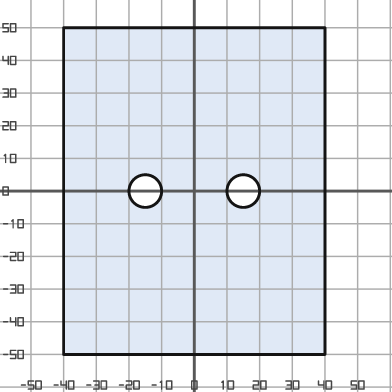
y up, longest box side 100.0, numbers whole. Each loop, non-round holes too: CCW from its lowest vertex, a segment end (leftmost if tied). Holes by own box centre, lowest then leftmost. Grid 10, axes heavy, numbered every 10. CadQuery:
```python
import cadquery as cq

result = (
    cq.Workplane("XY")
    .moveTo(-40.0, -50.0)
    .lineTo(40.0, -50.0)
    .lineTo(40.0, 50.0)
    .lineTo(-40.0, 50.0)
    .close()
    .moveTo(-15.0, 0.0)
    .circle(5.0)
    .moveTo(15.0, 0.0)
    .circle(5.0)
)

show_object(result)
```